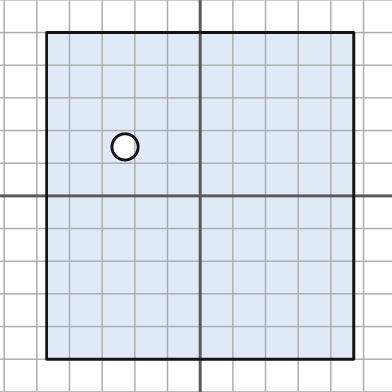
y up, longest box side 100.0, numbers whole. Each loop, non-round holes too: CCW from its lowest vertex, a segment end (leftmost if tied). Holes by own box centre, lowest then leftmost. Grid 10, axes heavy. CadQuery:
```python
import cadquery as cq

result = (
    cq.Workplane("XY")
    .moveTo(-47.0, -50.0)
    .lineTo(47.0, -50.0)
    .lineTo(47.0, 50.0)
    .lineTo(-47.0, 50.0)
    .close()
    .moveTo(-23.0, 15.0)
    .circle(4.0)
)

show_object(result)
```